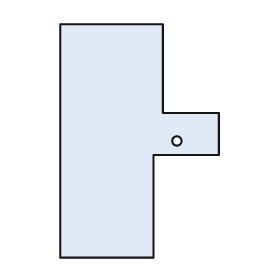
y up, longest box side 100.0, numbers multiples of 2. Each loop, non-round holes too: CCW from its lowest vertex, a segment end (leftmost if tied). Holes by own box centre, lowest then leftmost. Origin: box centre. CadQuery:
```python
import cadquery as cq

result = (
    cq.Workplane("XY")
    .moveTo(-34.0, -50.0)
    .lineTo(6.0, -50.0)
    .lineTo(6.0, -6.0)
    .lineTo(34.0, -6.0)
    .lineTo(34.0, 12.0)
    .lineTo(10.0, 12.0)
    .lineTo(10.0, 50.0)
    .lineTo(-34.0, 50.0)
    .close()
    .moveTo(16.0, 0.0)
    .circle(2.0)
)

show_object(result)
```